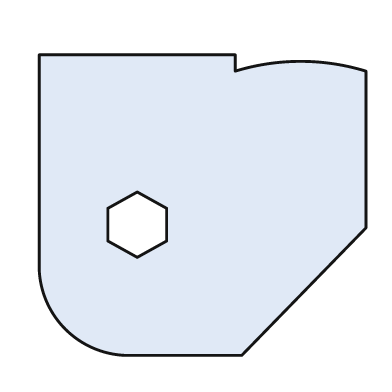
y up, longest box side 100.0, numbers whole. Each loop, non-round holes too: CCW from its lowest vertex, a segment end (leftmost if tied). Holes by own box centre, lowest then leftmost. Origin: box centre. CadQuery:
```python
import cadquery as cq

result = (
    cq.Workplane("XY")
    .moveTo(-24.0, -46.0)
    .lineTo(12.0, -46.0)
    .lineTo(50.0, -7.0)
    .lineTo(50.0, 41.0)
    .threePointArc((30.0, 44.0), (10.0, 41.0))
    .lineTo(10.0, 46.0)
    .lineTo(-50.0, 46.0)
    .lineTo(-50.0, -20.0)
    .threePointArc((-42.0, -38.0), (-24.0, -46.0))
    .close()
    .moveTo(-20.0, -16.0)
    .lineTo(-11.0, -11.0)
    .lineTo(-11.0, -1.0)
    .lineTo(-20.0, 4.0)
    .lineTo(-29.0, -1.0)
    .lineTo(-29.0, -11.0)
    .close()
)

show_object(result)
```